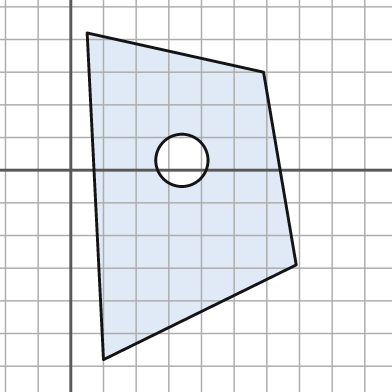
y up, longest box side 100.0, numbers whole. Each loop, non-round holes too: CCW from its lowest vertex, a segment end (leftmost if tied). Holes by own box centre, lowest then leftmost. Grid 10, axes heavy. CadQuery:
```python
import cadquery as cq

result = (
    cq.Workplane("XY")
    .moveTo(10.0, -58.0)
    .lineTo(69.0, -29.0)
    .lineTo(59.0, 30.0)
    .lineTo(5.0, 42.0)
    .close()
    .moveTo(34.0, 3.0)
    .circle(8.0)
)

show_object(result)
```